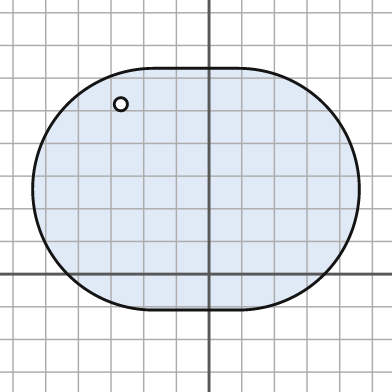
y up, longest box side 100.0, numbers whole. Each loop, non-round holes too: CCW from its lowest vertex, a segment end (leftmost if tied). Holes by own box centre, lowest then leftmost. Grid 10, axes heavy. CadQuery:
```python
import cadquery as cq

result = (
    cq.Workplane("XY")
    .moveTo(-17.0, -11.0)
    .lineTo(9.0, -11.0)
    .threePointArc((46.0, 26.0), (9.0, 63.0))
    .lineTo(-17.0, 63.0)
    .threePointArc((-54.0, 26.0), (-17.0, -11.0))
    .close()
    .moveTo(-27.0, 52.0)
    .circle(2.0)
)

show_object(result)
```